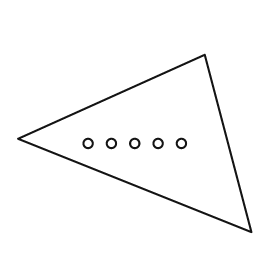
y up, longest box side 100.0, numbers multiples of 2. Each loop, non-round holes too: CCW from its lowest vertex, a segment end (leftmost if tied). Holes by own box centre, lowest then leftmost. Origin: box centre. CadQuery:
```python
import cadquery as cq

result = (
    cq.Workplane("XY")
    .moveTo(50.0, -38.0)
    .lineTo(30.0, 38.0)
    .lineTo(-50.0, 2.0)
    .close()
    .moveTo(-20.0, 0.0)
    .circle(2.0)
    .moveTo(-10.0, 0.0)
    .circle(2.0)
    .moveTo(0.0, 0.0)
    .circle(2.0)
    .moveTo(10.0, 0.0)
    .circle(2.0)
    .moveTo(20.0, 0.0)
    .circle(2.0)
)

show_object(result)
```